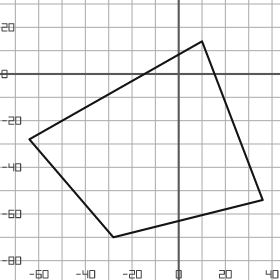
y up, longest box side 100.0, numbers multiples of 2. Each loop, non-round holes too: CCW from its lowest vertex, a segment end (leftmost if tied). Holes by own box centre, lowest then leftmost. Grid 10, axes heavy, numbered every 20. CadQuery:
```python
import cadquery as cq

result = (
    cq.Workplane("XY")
    .moveTo(-28.0, -70.0)
    .lineTo(36.0, -54.0)
    .lineTo(10.0, 14.0)
    .lineTo(-64.0, -28.0)
    .close()
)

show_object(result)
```